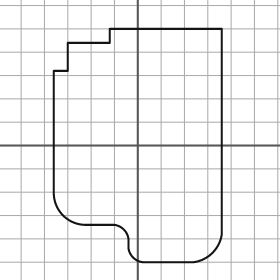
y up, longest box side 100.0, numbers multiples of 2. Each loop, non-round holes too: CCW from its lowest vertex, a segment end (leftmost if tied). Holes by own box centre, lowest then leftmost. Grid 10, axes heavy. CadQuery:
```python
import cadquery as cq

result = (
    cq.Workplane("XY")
    .moveTo(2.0, -50.0)
    .lineTo(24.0, -50.0)
    .threePointArc((32.0, -46.0), (36.0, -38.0))
    .lineTo(36.0, 50.0)
    .lineTo(-12.0, 50.0)
    .lineTo(-12.0, 44.0)
    .lineTo(-30.0, 44.0)
    .lineTo(-30.0, 32.0)
    .lineTo(-36.0, 32.0)
    .lineTo(-36.0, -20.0)
    .threePointArc((-32.0, -30.0), (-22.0, -34.0))
    .lineTo(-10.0, -34.0)
    .threePointArc((-6.0, -36.0), (-4.0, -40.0))
    .lineTo(-4.0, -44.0)
    .threePointArc((-2.0, -48.0), (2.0, -50.0))
    .close()
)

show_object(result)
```